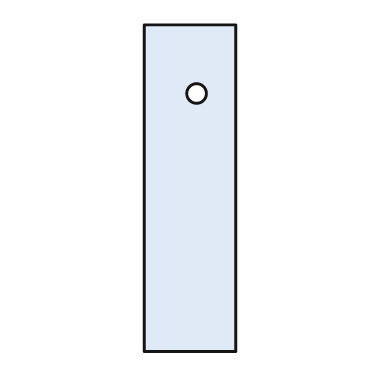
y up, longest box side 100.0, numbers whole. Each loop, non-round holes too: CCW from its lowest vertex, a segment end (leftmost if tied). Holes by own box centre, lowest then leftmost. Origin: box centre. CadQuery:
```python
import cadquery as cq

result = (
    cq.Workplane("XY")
    .moveTo(-14.0, -50.0)
    .lineTo(14.0, -50.0)
    .lineTo(14.0, 50.0)
    .lineTo(-14.0, 50.0)
    .close()
    .moveTo(2.0, 29.0)
    .circle(3.0)
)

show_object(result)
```